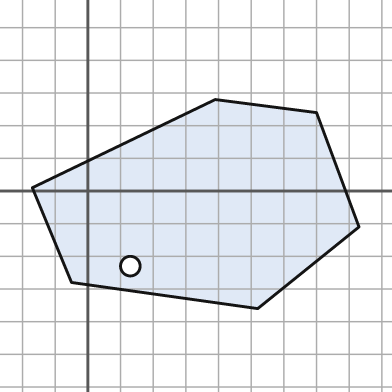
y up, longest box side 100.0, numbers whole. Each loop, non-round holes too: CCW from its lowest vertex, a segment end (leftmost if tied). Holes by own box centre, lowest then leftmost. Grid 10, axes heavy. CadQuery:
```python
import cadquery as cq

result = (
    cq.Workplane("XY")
    .moveTo(52.0, -36.0)
    .lineTo(83.0, -11.0)
    .lineTo(70.0, 24.0)
    .lineTo(39.0, 28.0)
    .lineTo(-17.0, 1.0)
    .lineTo(-5.0, -28.0)
    .close()
    .moveTo(13.0, -23.0)
    .circle(3.0)
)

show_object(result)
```